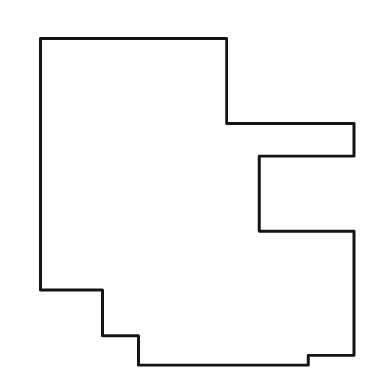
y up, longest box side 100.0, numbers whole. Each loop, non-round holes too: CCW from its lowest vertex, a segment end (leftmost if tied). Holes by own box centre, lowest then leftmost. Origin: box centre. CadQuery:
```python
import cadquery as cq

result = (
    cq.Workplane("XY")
    .moveTo(-18.0, -50.0)
    .lineTo(34.0, -50.0)
    .lineTo(34.0, -47.0)
    .lineTo(48.0, -47.0)
    .lineTo(48.0, -9.0)
    .lineTo(19.0, -9.0)
    .lineTo(19.0, 14.0)
    .lineTo(48.0, 14.0)
    .lineTo(48.0, 24.0)
    .lineTo(9.0, 24.0)
    .lineTo(9.0, 50.0)
    .lineTo(-48.0, 50.0)
    .lineTo(-48.0, -27.0)
    .lineTo(-29.0, -27.0)
    .lineTo(-29.0, -41.0)
    .lineTo(-18.0, -41.0)
    .close()
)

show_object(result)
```